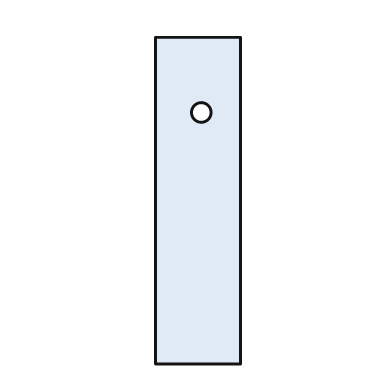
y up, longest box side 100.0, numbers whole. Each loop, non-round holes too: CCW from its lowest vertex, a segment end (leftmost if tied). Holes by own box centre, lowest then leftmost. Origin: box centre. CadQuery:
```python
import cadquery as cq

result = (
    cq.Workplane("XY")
    .moveTo(-13.0, -50.0)
    .lineTo(13.0, -50.0)
    .lineTo(13.0, 50.0)
    .lineTo(-13.0, 50.0)
    .close()
    .moveTo(1.0, 27.0)
    .circle(3.0)
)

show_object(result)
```